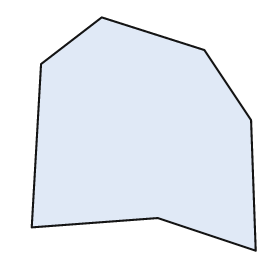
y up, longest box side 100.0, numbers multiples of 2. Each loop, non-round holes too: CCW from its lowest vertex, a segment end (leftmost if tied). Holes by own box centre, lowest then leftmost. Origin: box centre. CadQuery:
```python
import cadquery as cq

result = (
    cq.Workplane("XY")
    .moveTo(48.0, -50.0)
    .lineTo(46.0, 6.0)
    .lineTo(26.0, 36.0)
    .lineTo(-18.0, 50.0)
    .lineTo(-44.0, 30.0)
    .lineTo(-48.0, -40.0)
    .lineTo(6.0, -36.0)
    .close()
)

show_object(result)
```